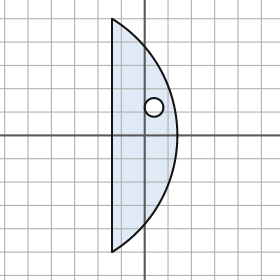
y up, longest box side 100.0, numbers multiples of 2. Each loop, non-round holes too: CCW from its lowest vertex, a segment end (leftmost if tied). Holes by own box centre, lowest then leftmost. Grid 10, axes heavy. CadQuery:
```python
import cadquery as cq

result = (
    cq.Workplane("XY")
    .moveTo(-14.0, -50.0)
    .threePointArc((14.0, 0.0), (-14.0, 50.0))
    .close()
    .moveTo(4.0, 12.0)
    .circle(4.0)
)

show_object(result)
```